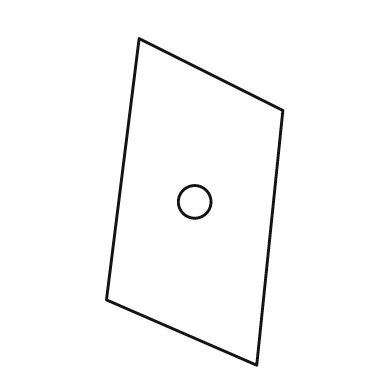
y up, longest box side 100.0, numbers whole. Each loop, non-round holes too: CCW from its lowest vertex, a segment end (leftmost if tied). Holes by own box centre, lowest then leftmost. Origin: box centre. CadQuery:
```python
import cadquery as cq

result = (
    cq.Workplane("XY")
    .moveTo(19.0, -50.0)
    .lineTo(27.0, 28.0)
    .lineTo(-17.0, 50.0)
    .lineTo(-27.0, -30.0)
    .close()
    .moveTo(0.0, 0.0)
    .circle(5.0)
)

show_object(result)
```